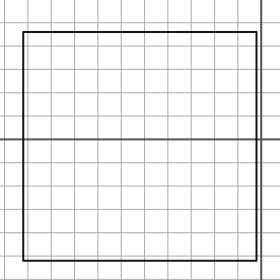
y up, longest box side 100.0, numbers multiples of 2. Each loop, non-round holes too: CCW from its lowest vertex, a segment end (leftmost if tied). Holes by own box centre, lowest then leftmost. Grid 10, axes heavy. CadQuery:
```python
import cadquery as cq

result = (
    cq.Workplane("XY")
    .moveTo(-102.0, -52.0)
    .lineTo(-2.0, -52.0)
    .lineTo(-2.0, 46.0)
    .lineTo(-102.0, 46.0)
    .close()
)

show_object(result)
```